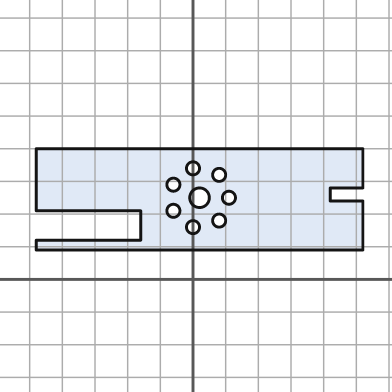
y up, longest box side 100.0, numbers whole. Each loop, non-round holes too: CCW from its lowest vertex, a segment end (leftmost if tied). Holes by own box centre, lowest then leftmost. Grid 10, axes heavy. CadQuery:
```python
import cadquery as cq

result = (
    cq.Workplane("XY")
    .moveTo(-48.0, 9.0)
    .lineTo(52.0, 9.0)
    .lineTo(52.0, 24.0)
    .lineTo(42.0, 24.0)
    .lineTo(42.0, 28.0)
    .lineTo(52.0, 28.0)
    .lineTo(52.0, 40.0)
    .lineTo(-48.0, 40.0)
    .lineTo(-48.0, 21.0)
    .lineTo(-16.0, 21.0)
    .lineTo(-16.0, 12.0)
    .lineTo(-48.0, 12.0)
    .close()
    .moveTo(0.0, 16.0)
    .circle(2.0)
    .moveTo(8.0, 18.0)
    .circle(2.0)
    .moveTo(-6.0, 21.0)
    .circle(2.0)
    .moveTo(2.0, 25.0)
    .circle(3.0)
    .moveTo(11.0, 25.0)
    .circle(2.0)
    .moveTo(-6.0, 29.0)
    .circle(2.0)
    .moveTo(8.0, 32.0)
    .circle(2.0)
    .moveTo(0.0, 34.0)
    .circle(2.0)
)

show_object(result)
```